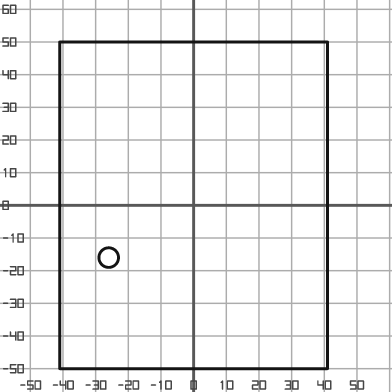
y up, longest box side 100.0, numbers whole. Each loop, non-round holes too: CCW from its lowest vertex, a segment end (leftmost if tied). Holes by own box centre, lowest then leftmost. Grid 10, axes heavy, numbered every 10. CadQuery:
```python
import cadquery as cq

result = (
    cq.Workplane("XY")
    .moveTo(-41.0, -50.0)
    .lineTo(41.0, -50.0)
    .lineTo(41.0, 50.0)
    .lineTo(-41.0, 50.0)
    .close()
    .moveTo(-26.0, -16.0)
    .circle(3.0)
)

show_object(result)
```